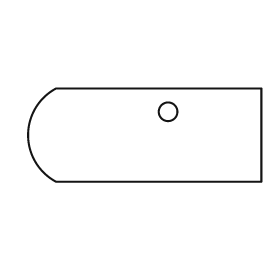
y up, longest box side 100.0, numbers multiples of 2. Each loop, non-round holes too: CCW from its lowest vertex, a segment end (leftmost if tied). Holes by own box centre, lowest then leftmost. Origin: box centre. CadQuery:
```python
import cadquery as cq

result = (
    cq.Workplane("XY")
    .moveTo(-38.0, -20.0)
    .lineTo(50.0, -20.0)
    .lineTo(50.0, 20.0)
    .lineTo(-38.0, 20.0)
    .threePointArc((-50.0, 0.0), (-38.0, -20.0))
    .close()
    .moveTo(10.0, 10.0)
    .circle(4.0)
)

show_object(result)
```